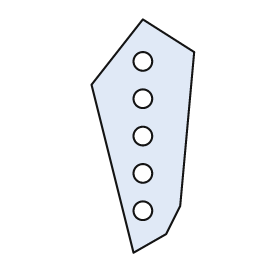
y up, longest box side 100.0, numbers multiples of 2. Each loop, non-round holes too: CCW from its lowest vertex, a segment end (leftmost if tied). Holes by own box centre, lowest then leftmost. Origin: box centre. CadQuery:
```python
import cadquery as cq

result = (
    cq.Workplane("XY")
    .moveTo(-4.0, -50.0)
    .lineTo(10.0, -42.0)
    .lineTo(16.0, -30.0)
    .lineTo(22.0, 36.0)
    .lineTo(0.0, 50.0)
    .lineTo(-22.0, 22.0)
    .close()
    .moveTo(0.0, -32.0)
    .circle(4.0)
    .moveTo(0.0, -16.0)
    .circle(4.0)
    .moveTo(0.0, 0.0)
    .circle(4.0)
    .moveTo(0.0, 16.0)
    .circle(4.0)
    .moveTo(0.0, 32.0)
    .circle(4.0)
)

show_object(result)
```